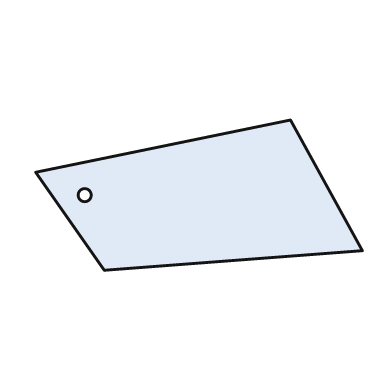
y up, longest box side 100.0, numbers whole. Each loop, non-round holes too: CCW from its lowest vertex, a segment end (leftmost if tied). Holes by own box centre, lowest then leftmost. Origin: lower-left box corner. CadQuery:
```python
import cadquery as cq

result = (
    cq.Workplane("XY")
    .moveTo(21.0, 0.0)
    .lineTo(100.0, 6.0)
    .lineTo(78.0, 46.0)
    .lineTo(0.0, 30.0)
    .close()
    .moveTo(15.0, 23.0)
    .circle(2.0)
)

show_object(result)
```